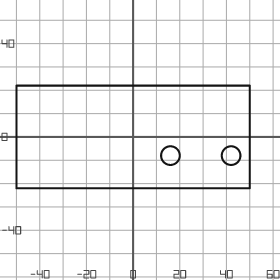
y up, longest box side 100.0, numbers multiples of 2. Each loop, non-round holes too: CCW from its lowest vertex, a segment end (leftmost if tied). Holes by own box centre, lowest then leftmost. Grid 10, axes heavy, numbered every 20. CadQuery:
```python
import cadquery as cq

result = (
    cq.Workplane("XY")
    .moveTo(-50.0, -22.0)
    .lineTo(50.0, -22.0)
    .lineTo(50.0, 22.0)
    .lineTo(-50.0, 22.0)
    .close()
    .moveTo(16.0, -8.0)
    .circle(4.0)
    .moveTo(42.0, -8.0)
    .circle(4.0)
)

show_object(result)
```